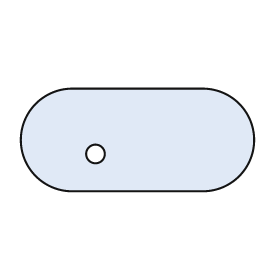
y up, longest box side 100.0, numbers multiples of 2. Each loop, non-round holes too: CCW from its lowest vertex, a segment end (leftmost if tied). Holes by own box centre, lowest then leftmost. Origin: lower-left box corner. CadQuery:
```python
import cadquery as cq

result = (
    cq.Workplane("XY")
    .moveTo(22.0, 0.0)
    .lineTo(78.0, 0.0)
    .threePointArc((100.0, 22.0), (78.0, 44.0))
    .lineTo(22.0, 44.0)
    .threePointArc((0.0, 22.0), (22.0, 0.0))
    .close()
    .moveTo(32.0, 16.0)
    .circle(4.0)
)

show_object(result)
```